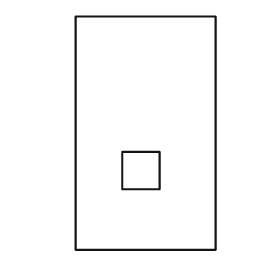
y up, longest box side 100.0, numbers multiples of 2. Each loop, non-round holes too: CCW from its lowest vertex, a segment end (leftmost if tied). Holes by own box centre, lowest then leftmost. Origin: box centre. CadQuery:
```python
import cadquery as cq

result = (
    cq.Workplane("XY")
    .moveTo(-30.0, -50.0)
    .lineTo(30.0, -50.0)
    .lineTo(30.0, 50.0)
    .lineTo(-30.0, 50.0)
    .close()
    .moveTo(-10.0, -24.0)
    .lineTo(6.0, -24.0)
    .lineTo(6.0, -8.0)
    .lineTo(-10.0, -8.0)
    .close()
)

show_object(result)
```